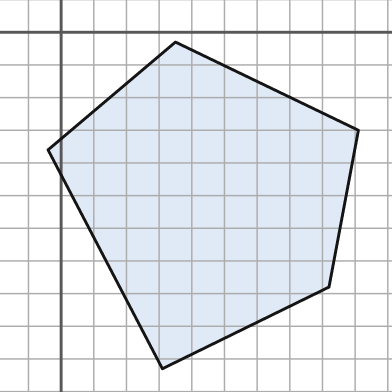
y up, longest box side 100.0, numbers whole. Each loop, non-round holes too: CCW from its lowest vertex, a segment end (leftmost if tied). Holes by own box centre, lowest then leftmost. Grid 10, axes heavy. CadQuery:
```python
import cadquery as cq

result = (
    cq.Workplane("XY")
    .moveTo(31.0, -103.0)
    .lineTo(82.0, -78.0)
    .lineTo(91.0, -30.0)
    .lineTo(35.0, -3.0)
    .lineTo(-4.0, -36.0)
    .close()
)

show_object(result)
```